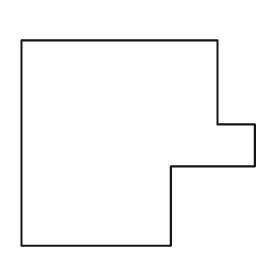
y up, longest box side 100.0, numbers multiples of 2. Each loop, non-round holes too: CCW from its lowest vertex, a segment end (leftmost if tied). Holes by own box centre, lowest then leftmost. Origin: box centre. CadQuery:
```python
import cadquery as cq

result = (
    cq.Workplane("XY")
    .moveTo(-50.0, -44.0)
    .lineTo(14.0, -44.0)
    .lineTo(14.0, -10.0)
    .lineTo(50.0, -10.0)
    .lineTo(50.0, 8.0)
    .lineTo(34.0, 8.0)
    .lineTo(34.0, 44.0)
    .lineTo(-50.0, 44.0)
    .close()
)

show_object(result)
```